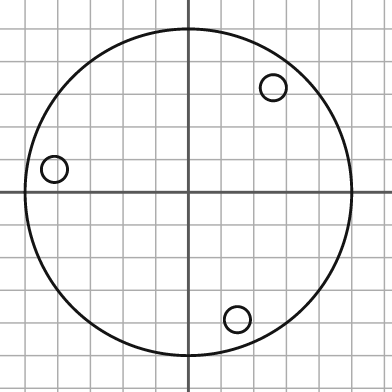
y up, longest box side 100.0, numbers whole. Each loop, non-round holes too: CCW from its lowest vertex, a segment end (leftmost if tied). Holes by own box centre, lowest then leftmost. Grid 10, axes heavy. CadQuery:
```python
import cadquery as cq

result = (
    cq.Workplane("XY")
    .moveTo(0.0, 0.0)
    .circle(50.0)
    .moveTo(15.0, -39.0)
    .circle(4.0)
    .moveTo(-41.0, 7.0)
    .circle(4.0)
    .moveTo(26.0, 32.0)
    .circle(4.0)
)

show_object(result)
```